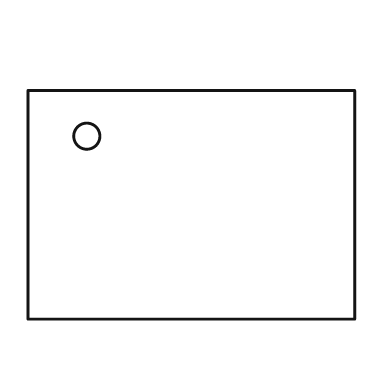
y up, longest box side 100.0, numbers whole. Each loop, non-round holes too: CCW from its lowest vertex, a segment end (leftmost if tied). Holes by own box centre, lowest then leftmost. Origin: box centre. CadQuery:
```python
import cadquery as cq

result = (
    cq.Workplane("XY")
    .moveTo(-50.0, -35.0)
    .lineTo(50.0, -35.0)
    .lineTo(50.0, 35.0)
    .lineTo(-50.0, 35.0)
    .close()
    .moveTo(-32.0, 21.0)
    .circle(4.0)
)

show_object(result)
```